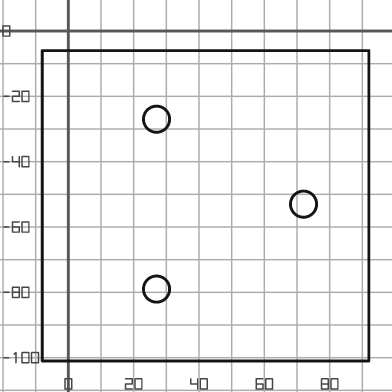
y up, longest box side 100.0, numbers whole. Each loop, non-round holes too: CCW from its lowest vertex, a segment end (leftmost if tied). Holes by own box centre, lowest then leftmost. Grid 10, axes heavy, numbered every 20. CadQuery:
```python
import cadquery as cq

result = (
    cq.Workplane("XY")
    .moveTo(-8.0, -101.0)
    .lineTo(92.0, -101.0)
    .lineTo(92.0, -6.0)
    .lineTo(-8.0, -6.0)
    .close()
    .moveTo(27.0, -79.0)
    .circle(4.0)
    .moveTo(72.0, -53.0)
    .circle(4.0)
    .moveTo(27.0, -27.0)
    .circle(4.0)
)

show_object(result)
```